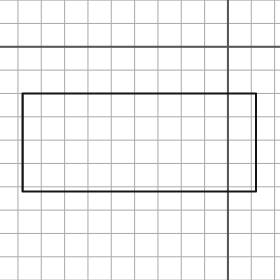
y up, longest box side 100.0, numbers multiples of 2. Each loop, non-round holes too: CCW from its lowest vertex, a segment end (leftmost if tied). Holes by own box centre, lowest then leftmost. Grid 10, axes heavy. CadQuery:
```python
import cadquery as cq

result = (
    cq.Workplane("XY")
    .moveTo(-88.0, -62.0)
    .lineTo(12.0, -62.0)
    .lineTo(12.0, -20.0)
    .lineTo(-88.0, -20.0)
    .close()
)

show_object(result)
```